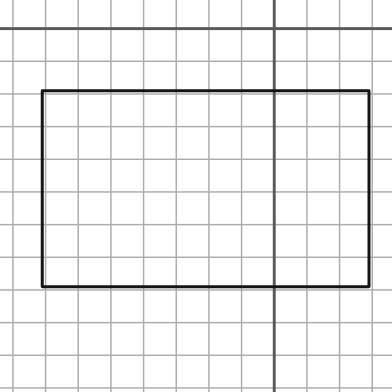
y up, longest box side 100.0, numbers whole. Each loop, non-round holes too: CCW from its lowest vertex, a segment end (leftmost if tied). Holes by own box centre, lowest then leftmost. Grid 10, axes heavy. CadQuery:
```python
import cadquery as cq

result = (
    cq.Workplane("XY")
    .moveTo(-71.0, -79.0)
    .lineTo(29.0, -79.0)
    .lineTo(29.0, -19.0)
    .lineTo(-71.0, -19.0)
    .close()
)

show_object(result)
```